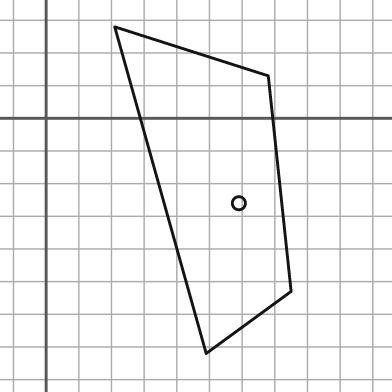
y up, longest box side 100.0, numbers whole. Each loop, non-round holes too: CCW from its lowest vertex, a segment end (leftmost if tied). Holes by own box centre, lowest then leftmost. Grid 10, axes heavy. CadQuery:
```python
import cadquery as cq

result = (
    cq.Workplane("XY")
    .moveTo(49.0, -72.0)
    .lineTo(75.0, -53.0)
    .lineTo(68.0, 13.0)
    .lineTo(21.0, 28.0)
    .close()
    .moveTo(59.0, -26.0)
    .circle(2.0)
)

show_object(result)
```